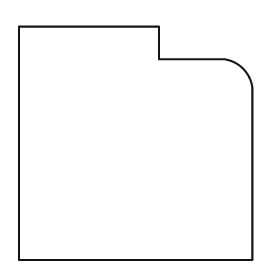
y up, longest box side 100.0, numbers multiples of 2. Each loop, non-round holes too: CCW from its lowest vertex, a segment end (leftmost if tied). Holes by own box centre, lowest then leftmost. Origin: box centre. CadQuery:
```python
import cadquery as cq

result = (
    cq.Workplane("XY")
    .moveTo(-50.0, -50.0)
    .lineTo(50.0, -50.0)
    .lineTo(50.0, 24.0)
    .threePointArc((46.0, 32.0), (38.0, 36.0))
    .lineTo(10.0, 36.0)
    .lineTo(10.0, 50.0)
    .lineTo(-50.0, 50.0)
    .close()
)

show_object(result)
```